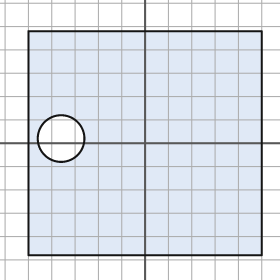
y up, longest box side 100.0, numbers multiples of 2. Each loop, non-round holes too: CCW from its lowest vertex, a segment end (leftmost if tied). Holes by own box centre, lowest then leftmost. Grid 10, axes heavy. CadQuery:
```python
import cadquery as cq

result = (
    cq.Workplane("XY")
    .moveTo(-50.0, -48.0)
    .lineTo(50.0, -48.0)
    .lineTo(50.0, 48.0)
    .lineTo(-50.0, 48.0)
    .close()
    .moveTo(-36.0, 2.0)
    .circle(10.0)
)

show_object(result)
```